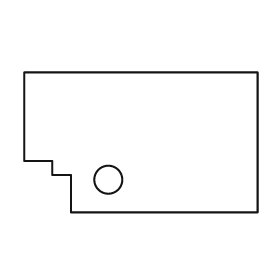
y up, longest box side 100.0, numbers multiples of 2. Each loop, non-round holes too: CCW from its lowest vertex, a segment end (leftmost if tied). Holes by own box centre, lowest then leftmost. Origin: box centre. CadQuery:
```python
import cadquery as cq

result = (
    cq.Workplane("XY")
    .moveTo(-30.0, -30.0)
    .lineTo(50.0, -30.0)
    .lineTo(50.0, 30.0)
    .lineTo(-50.0, 30.0)
    .lineTo(-50.0, -8.0)
    .lineTo(-38.0, -8.0)
    .lineTo(-38.0, -14.0)
    .lineTo(-30.0, -14.0)
    .close()
    .moveTo(-14.0, -16.0)
    .circle(6.0)
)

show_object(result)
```